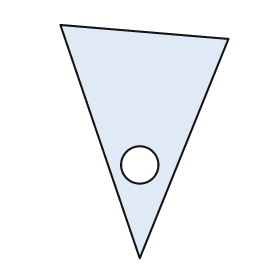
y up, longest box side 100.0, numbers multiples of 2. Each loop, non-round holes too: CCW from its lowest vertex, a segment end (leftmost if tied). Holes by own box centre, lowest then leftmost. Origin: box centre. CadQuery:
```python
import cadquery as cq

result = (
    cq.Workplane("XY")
    .moveTo(-2.0, -50.0)
    .lineTo(36.0, 44.0)
    .lineTo(-36.0, 50.0)
    .close()
    .moveTo(-2.0, -10.0)
    .circle(8.0)
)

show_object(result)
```